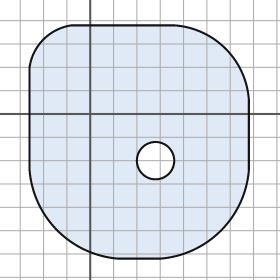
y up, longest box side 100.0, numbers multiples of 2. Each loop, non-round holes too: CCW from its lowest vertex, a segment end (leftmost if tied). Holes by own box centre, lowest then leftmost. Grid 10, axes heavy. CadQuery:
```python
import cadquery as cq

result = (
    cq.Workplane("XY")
    .moveTo(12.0, -62.0)
    .lineTo(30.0, -62.0)
    .threePointArc((56.0, -50.0), (68.0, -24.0))
    .lineTo(68.0, 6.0)
    .threePointArc((58.0, 28.0), (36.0, 38.0))
    .lineTo(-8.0, 38.0)
    .threePointArc((-20.0, 32.0), (-26.0, 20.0))
    .lineTo(-26.0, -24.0)
    .threePointArc((-14.0, -50.0), (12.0, -62.0))
    .close()
    .moveTo(28.0, -20.0)
    .circle(8.0)
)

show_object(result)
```